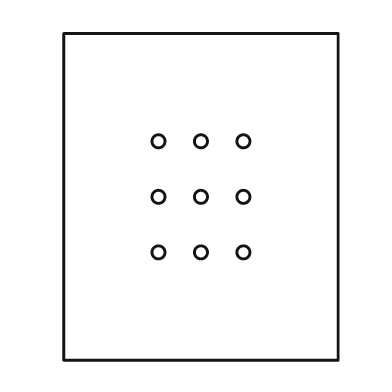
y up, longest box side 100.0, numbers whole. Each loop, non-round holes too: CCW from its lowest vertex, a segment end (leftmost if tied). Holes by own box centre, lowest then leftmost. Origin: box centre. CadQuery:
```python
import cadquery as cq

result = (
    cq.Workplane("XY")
    .moveTo(-42.0, -50.0)
    .lineTo(42.0, -50.0)
    .lineTo(42.0, 50.0)
    .lineTo(-42.0, 50.0)
    .close()
    .moveTo(-13.0, -17.0)
    .circle(2.0)
    .moveTo(0.0, -17.0)
    .circle(2.0)
    .moveTo(13.0, -17.0)
    .circle(2.0)
    .moveTo(-13.0, 0.0)
    .circle(2.0)
    .moveTo(0.0, 0.0)
    .circle(2.0)
    .moveTo(13.0, 0.0)
    .circle(2.0)
    .moveTo(-13.0, 17.0)
    .circle(2.0)
    .moveTo(0.0, 17.0)
    .circle(2.0)
    .moveTo(13.0, 17.0)
    .circle(2.0)
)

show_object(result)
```